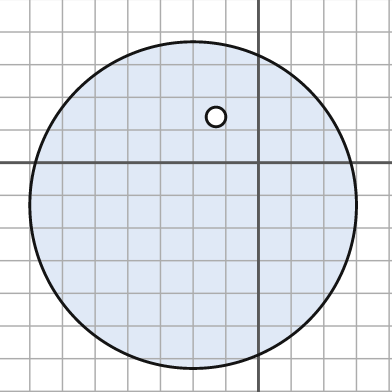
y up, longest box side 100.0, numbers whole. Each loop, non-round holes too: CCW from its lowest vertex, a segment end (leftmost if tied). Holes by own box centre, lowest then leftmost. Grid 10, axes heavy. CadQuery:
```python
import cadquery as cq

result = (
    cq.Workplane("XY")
    .moveTo(-20.0, -13.0)
    .circle(50.0)
    .moveTo(-13.0, 14.0)
    .circle(3.0)
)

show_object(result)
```